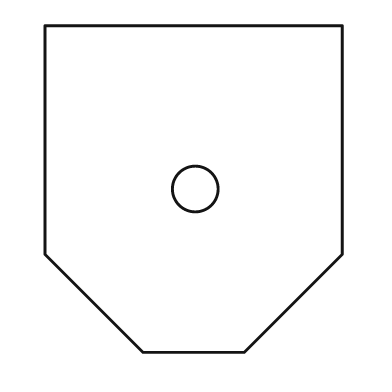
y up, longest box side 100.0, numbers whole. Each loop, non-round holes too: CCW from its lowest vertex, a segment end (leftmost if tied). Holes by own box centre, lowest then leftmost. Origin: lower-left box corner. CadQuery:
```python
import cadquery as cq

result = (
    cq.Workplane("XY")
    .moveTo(30.0, 0.0)
    .lineTo(61.0, 0.0)
    .lineTo(91.0, 30.0)
    .lineTo(91.0, 100.0)
    .lineTo(0.0, 100.0)
    .lineTo(0.0, 30.0)
    .close()
    .moveTo(46.0, 50.0)
    .circle(7.0)
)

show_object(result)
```